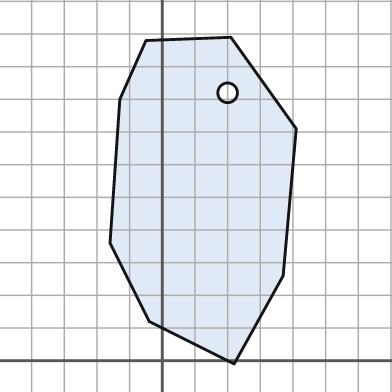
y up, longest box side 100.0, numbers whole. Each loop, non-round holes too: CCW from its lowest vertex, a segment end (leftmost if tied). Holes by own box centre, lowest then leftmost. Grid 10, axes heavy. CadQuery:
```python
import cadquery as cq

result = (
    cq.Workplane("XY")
    .moveTo(22.0, -1.0)
    .lineTo(37.0, 26.0)
    .lineTo(41.0, 71.0)
    .lineTo(21.0, 99.0)
    .lineTo(-5.0, 98.0)
    .lineTo(-13.0, 80.0)
    .lineTo(-16.0, 36.0)
    .lineTo(-4.0, 12.0)
    .close()
    .moveTo(20.0, 82.0)
    .circle(3.0)
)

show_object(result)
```